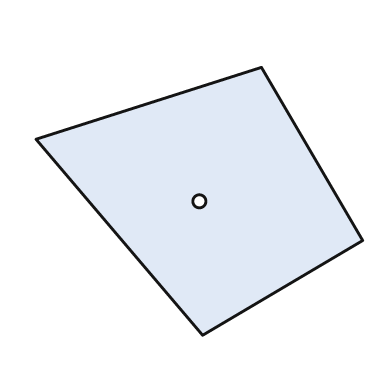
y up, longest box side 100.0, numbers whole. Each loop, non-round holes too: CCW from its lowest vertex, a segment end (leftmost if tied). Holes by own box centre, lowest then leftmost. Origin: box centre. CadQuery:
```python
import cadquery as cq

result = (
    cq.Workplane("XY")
    .moveTo(1.0, -41.0)
    .lineTo(50.0, -12.0)
    .lineTo(19.0, 41.0)
    .lineTo(-50.0, 19.0)
    .close()
    .moveTo(0.0, 0.0)
    .circle(2.0)
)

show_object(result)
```